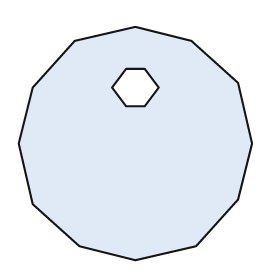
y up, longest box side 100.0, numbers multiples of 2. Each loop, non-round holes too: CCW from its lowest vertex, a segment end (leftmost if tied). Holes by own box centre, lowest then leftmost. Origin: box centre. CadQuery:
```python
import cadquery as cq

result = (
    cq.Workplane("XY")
    .moveTo(0.0, -50.0)
    .lineTo(26.0, -44.0)
    .lineTo(44.0, -24.0)
    .lineTo(50.0, 0.0)
    .lineTo(44.0, 26.0)
    .lineTo(24.0, 44.0)
    .lineTo(0.0, 50.0)
    .lineTo(-26.0, 44.0)
    .lineTo(-44.0, 24.0)
    .lineTo(-50.0, 0.0)
    .lineTo(-44.0, -26.0)
    .lineTo(-24.0, -44.0)
    .close()
    .moveTo(-4.0, 16.0)
    .lineTo(4.0, 16.0)
    .lineTo(10.0, 24.0)
    .lineTo(4.0, 32.0)
    .lineTo(-4.0, 32.0)
    .lineTo(-10.0, 24.0)
    .close()
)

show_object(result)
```